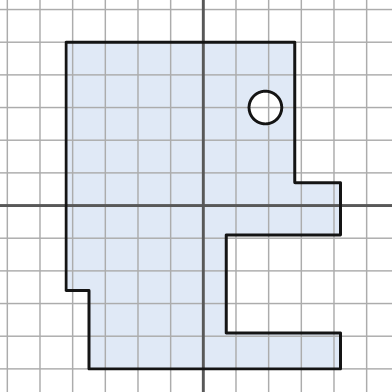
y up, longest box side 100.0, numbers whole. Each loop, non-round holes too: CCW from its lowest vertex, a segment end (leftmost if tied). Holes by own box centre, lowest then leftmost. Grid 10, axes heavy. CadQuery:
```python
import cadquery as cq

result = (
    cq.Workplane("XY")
    .moveTo(-35.0, -50.0)
    .lineTo(42.0, -50.0)
    .lineTo(42.0, -39.0)
    .lineTo(7.0, -39.0)
    .lineTo(7.0, -9.0)
    .lineTo(42.0, -9.0)
    .lineTo(42.0, 7.0)
    .lineTo(28.0, 7.0)
    .lineTo(28.0, 50.0)
    .lineTo(-42.0, 50.0)
    .lineTo(-42.0, -26.0)
    .lineTo(-35.0, -26.0)
    .close()
    .moveTo(19.0, 30.0)
    .circle(5.0)
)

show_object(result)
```